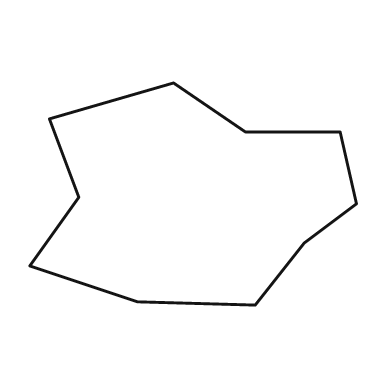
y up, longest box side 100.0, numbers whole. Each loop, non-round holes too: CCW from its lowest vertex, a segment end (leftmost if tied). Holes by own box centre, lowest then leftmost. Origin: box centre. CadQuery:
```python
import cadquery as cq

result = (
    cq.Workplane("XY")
    .moveTo(19.0, -34.0)
    .lineTo(34.0, -15.0)
    .lineTo(50.0, -3.0)
    .lineTo(45.0, 19.0)
    .lineTo(16.0, 19.0)
    .lineTo(-6.0, 34.0)
    .lineTo(-44.0, 23.0)
    .lineTo(-35.0, -1.0)
    .lineTo(-50.0, -22.0)
    .lineTo(-17.0, -33.0)
    .close()
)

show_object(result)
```